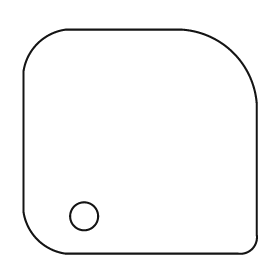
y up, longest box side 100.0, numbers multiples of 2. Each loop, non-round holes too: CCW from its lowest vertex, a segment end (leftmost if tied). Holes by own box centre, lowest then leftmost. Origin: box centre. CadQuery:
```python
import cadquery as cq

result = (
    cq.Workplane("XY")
    .moveTo(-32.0, -48.0)
    .lineTo(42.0, -48.0)
    .threePointArc((48.0, -46.0), (50.0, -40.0))
    .lineTo(50.0, 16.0)
    .threePointArc((40.0, 38.0), (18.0, 48.0))
    .lineTo(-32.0, 48.0)
    .threePointArc((-44.0, 42.0), (-50.0, 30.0))
    .lineTo(-50.0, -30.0)
    .threePointArc((-44.0, -42.0), (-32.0, -48.0))
    .close()
    .moveTo(-24.0, -32.0)
    .circle(6.0)
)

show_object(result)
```